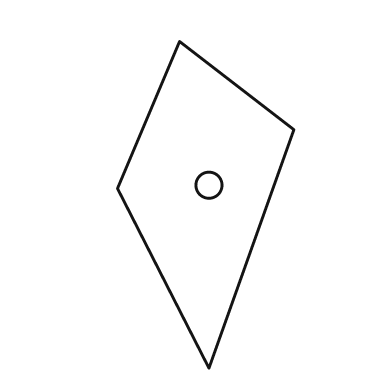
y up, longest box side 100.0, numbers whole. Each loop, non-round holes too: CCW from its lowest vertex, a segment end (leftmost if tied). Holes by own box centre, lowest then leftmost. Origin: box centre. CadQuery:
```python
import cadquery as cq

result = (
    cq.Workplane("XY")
    .moveTo(1.0, -50.0)
    .lineTo(27.0, 23.0)
    .lineTo(-8.0, 50.0)
    .lineTo(-27.0, 5.0)
    .close()
    .moveTo(1.0, 6.0)
    .circle(4.0)
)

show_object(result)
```